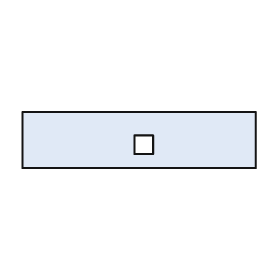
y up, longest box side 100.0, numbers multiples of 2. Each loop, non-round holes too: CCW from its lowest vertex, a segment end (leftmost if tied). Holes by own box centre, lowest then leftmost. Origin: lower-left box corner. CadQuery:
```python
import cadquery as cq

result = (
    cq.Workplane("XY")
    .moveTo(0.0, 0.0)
    .lineTo(100.0, 0.0)
    .lineTo(100.0, 24.0)
    .lineTo(0.0, 24.0)
    .close()
    .moveTo(48.0, 6.0)
    .lineTo(56.0, 6.0)
    .lineTo(56.0, 14.0)
    .lineTo(48.0, 14.0)
    .close()
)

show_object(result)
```